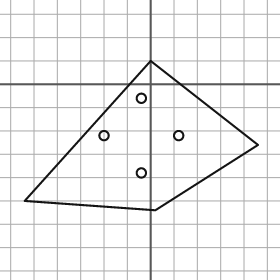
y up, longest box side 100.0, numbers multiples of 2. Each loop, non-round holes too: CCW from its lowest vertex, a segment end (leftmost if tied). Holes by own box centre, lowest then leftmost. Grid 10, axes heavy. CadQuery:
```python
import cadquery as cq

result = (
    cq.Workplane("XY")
    .moveTo(2.0, -54.0)
    .lineTo(46.0, -26.0)
    .lineTo(0.0, 10.0)
    .lineTo(-54.0, -50.0)
    .close()
    .moveTo(-4.0, -38.0)
    .circle(2.0)
    .moveTo(-20.0, -22.0)
    .circle(2.0)
    .moveTo(12.0, -22.0)
    .circle(2.0)
    .moveTo(-4.0, -6.0)
    .circle(2.0)
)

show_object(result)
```